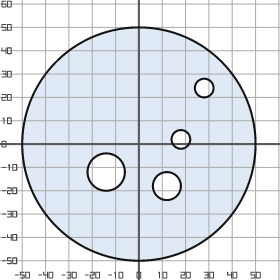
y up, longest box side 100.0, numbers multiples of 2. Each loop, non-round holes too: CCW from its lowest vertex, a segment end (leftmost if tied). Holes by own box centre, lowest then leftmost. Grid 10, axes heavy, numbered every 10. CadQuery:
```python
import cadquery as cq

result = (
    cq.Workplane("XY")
    .moveTo(0.0, 0.0)
    .circle(50.0)
    .moveTo(12.0, -18.0)
    .circle(6.0)
    .moveTo(-14.0, -12.0)
    .circle(8.0)
    .moveTo(18.0, 2.0)
    .circle(4.0)
    .moveTo(28.0, 24.0)
    .circle(4.0)
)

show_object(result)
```